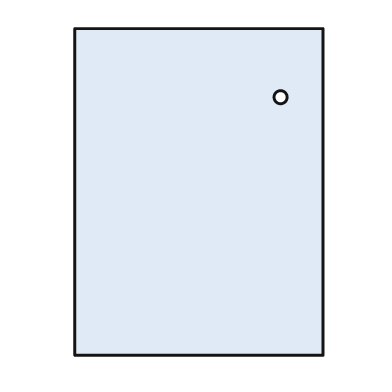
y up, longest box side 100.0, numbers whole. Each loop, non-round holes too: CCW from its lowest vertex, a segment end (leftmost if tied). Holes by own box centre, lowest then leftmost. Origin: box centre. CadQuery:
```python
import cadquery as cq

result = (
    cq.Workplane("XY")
    .moveTo(-38.0, -50.0)
    .lineTo(38.0, -50.0)
    .lineTo(38.0, 50.0)
    .lineTo(-38.0, 50.0)
    .close()
    .moveTo(25.0, 29.0)
    .circle(2.0)
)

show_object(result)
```